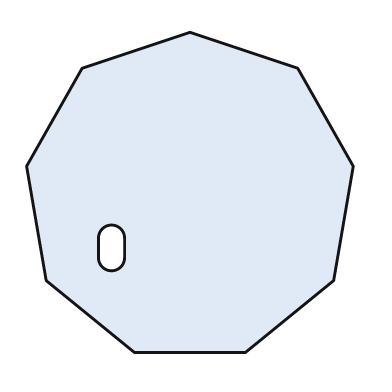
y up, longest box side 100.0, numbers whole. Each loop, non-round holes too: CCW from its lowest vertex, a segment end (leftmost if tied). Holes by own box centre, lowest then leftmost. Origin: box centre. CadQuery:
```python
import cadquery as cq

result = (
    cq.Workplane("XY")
    .moveTo(-17.0, -49.0)
    .lineTo(17.0, -49.0)
    .lineTo(44.0, -27.0)
    .lineTo(50.0, 8.0)
    .lineTo(33.0, 38.0)
    .lineTo(0.0, 49.0)
    .lineTo(-33.0, 38.0)
    .lineTo(-50.0, 8.0)
    .lineTo(-44.0, -27.0)
    .close()
    .moveTo(-28.0, -20.0)
    .threePointArc((-24.0, -24.0), (-20.0, -20.0))
    .lineTo(-20.0, -14.0)
    .threePointArc((-24.0, -10.0), (-28.0, -14.0))
    .close()
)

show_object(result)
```